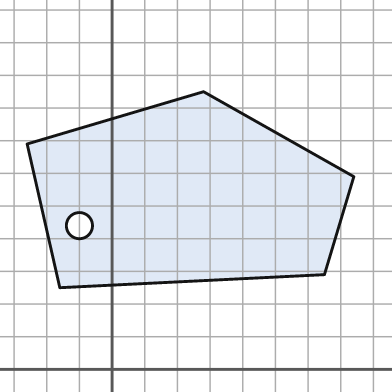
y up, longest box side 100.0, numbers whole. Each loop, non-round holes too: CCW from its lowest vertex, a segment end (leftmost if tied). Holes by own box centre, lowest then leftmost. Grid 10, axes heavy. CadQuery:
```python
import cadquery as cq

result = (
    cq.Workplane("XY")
    .moveTo(-16.0, 25.0)
    .lineTo(65.0, 29.0)
    .lineTo(74.0, 59.0)
    .lineTo(28.0, 85.0)
    .lineTo(-26.0, 69.0)
    .close()
    .moveTo(-10.0, 44.0)
    .circle(4.0)
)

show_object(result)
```